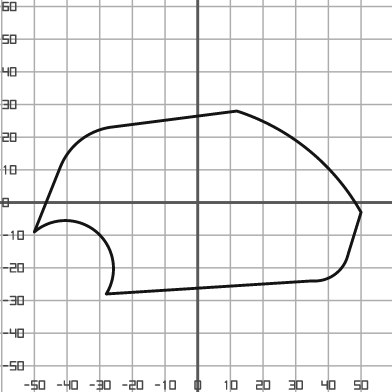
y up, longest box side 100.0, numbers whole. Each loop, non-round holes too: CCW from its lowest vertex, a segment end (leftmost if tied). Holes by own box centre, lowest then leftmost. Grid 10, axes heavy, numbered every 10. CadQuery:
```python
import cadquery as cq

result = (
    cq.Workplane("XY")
    .moveTo(-28.0, -28.0)
    .lineTo(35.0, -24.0)
    .threePointArc((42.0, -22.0), (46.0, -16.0))
    .lineTo(50.0, -3.0)
    .threePointArc((34.0, 16.0), (12.0, 28.0))
    .lineTo(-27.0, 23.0)
    .threePointArc((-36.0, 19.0), (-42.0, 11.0))
    .lineTo(-50.0, -9.0)
    .threePointArc((-31.0, -9.0), (-28.0, -28.0))
    .close()
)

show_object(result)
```